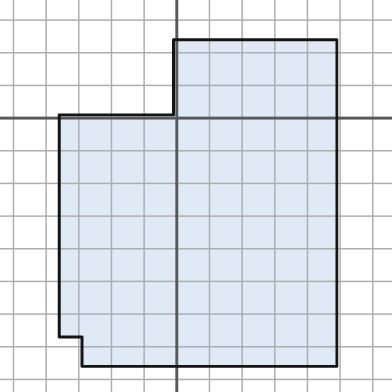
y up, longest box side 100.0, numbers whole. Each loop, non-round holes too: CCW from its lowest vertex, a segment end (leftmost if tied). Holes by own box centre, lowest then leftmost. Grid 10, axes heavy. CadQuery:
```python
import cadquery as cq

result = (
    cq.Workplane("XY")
    .moveTo(-29.0, -76.0)
    .lineTo(49.0, -76.0)
    .lineTo(49.0, 24.0)
    .lineTo(-1.0, 24.0)
    .lineTo(-1.0, 1.0)
    .lineTo(-36.0, 1.0)
    .lineTo(-36.0, -67.0)
    .lineTo(-29.0, -67.0)
    .close()
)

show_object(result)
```